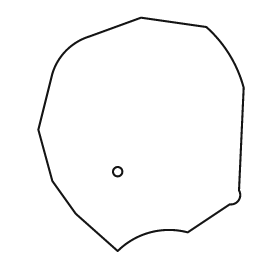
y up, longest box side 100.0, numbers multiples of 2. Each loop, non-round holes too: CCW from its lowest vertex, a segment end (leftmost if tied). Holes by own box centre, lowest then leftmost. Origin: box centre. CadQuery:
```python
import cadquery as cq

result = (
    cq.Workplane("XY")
    .moveTo(-10.0, -50.0)
    .threePointArc((4.0, -42.0), (20.0, -42.0))
    .lineTo(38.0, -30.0)
    .threePointArc((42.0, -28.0), (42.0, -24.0))
    .lineTo(44.0, 20.0)
    .threePointArc((38.0, 34.0), (28.0, 46.0))
    .lineTo(0.0, 50.0)
    .lineTo(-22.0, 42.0)
    .threePointArc((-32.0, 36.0), (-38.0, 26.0))
    .lineTo(-44.0, 2.0)
    .lineTo(-38.0, -20.0)
    .lineTo(-28.0, -34.0)
    .close()
    .moveTo(-10.0, -16.0)
    .circle(2.0)
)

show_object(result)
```